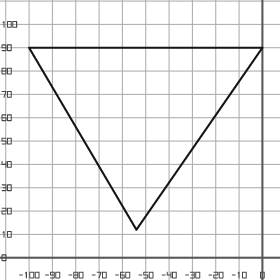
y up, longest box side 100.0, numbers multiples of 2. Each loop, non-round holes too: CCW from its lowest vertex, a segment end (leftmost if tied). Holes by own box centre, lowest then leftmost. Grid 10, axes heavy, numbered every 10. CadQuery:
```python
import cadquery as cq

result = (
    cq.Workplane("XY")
    .moveTo(-54.0, 12.0)
    .lineTo(0.0, 90.0)
    .lineTo(-100.0, 90.0)
    .close()
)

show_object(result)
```